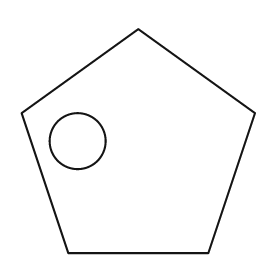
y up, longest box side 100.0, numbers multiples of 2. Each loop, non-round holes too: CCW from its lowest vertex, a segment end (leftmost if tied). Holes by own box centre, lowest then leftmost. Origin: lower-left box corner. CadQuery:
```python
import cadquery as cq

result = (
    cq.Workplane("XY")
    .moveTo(20.0, 0.0)
    .lineTo(80.0, 0.0)
    .lineTo(100.0, 60.0)
    .lineTo(50.0, 96.0)
    .lineTo(0.0, 60.0)
    .close()
    .moveTo(24.0, 48.0)
    .circle(12.0)
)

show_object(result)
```